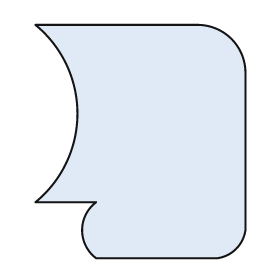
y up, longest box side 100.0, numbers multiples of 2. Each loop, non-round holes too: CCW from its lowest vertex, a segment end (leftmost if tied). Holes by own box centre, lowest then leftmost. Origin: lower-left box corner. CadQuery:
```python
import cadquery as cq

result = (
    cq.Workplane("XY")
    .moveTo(26.0, 0.0)
    .lineTo(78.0, 0.0)
    .threePointArc((86.0, 4.0), (90.0, 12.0))
    .lineTo(90.0, 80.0)
    .threePointArc((84.0, 94.0), (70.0, 100.0))
    .lineTo(0.0, 100.0)
    .threePointArc((18.0, 62.0), (0.0, 24.0))
    .lineTo(26.0, 24.0)
    .threePointArc((20.0, 12.0), (26.0, 0.0))
    .close()
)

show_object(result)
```